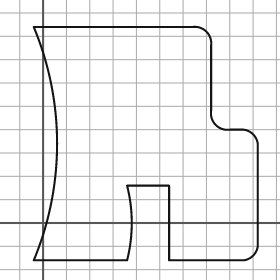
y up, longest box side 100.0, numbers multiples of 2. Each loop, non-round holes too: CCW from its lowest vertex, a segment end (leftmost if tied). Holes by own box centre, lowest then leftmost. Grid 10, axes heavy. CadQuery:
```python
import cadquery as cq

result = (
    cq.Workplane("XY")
    .moveTo(-4.0, -16.0)
    .lineTo(36.0, -16.0)
    .threePointArc((38.0, 0.0), (36.0, 16.0))
    .lineTo(54.0, 16.0)
    .lineTo(54.0, -16.0)
    .lineTo(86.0, -16.0)
    .threePointArc((90.0, -14.0), (92.0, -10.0))
    .lineTo(92.0, 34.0)
    .threePointArc((90.0, 38.0), (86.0, 40.0))
    .lineTo(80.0, 40.0)
    .threePointArc((74.0, 42.0), (72.0, 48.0))
    .lineTo(72.0, 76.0)
    .threePointArc((70.0, 82.0), (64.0, 84.0))
    .lineTo(-4.0, 84.0)
    .threePointArc((6.0, 34.0), (-4.0, -16.0))
    .close()
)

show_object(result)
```